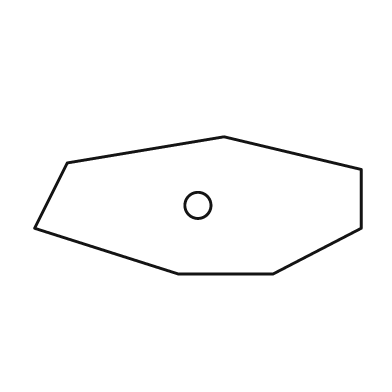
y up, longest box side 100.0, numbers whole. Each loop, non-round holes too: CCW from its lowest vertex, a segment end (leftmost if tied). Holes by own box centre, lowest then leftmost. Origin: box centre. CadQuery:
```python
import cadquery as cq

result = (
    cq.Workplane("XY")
    .moveTo(-6.0, -21.0)
    .lineTo(23.0, -21.0)
    .lineTo(50.0, -7.0)
    .lineTo(50.0, 11.0)
    .lineTo(8.0, 21.0)
    .lineTo(-40.0, 13.0)
    .lineTo(-50.0, -7.0)
    .close()
    .moveTo(0.0, 0.0)
    .circle(4.0)
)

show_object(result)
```